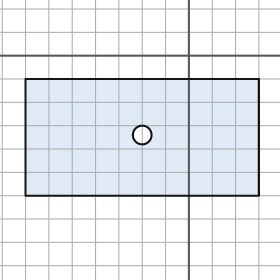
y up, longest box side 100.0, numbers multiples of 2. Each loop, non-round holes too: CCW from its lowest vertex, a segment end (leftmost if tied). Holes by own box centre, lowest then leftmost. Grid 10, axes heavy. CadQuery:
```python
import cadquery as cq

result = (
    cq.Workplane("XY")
    .moveTo(-70.0, -60.0)
    .lineTo(30.0, -60.0)
    .lineTo(30.0, -10.0)
    .lineTo(-70.0, -10.0)
    .close()
    .moveTo(-20.0, -34.0)
    .circle(4.0)
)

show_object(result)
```